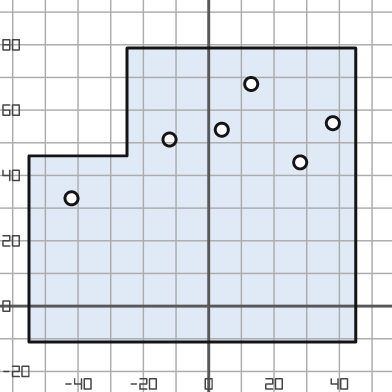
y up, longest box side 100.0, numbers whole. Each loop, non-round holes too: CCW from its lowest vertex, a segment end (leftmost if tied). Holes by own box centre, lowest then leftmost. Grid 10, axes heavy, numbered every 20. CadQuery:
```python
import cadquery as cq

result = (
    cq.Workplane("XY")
    .moveTo(-55.0, -11.0)
    .lineTo(45.0, -11.0)
    .lineTo(45.0, 79.0)
    .lineTo(-25.0, 79.0)
    .lineTo(-25.0, 46.0)
    .lineTo(-55.0, 46.0)
    .close()
    .moveTo(-42.0, 33.0)
    .circle(2.0)
    .moveTo(28.0, 44.0)
    .circle(2.0)
    .moveTo(-12.0, 51.0)
    .circle(2.0)
    .moveTo(4.0, 54.0)
    .circle(2.0)
    .moveTo(38.0, 56.0)
    .circle(2.0)
    .moveTo(13.0, 68.0)
    .circle(2.0)
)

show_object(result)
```